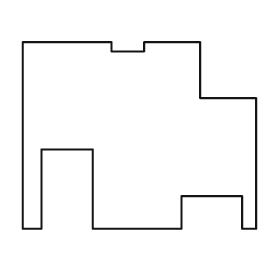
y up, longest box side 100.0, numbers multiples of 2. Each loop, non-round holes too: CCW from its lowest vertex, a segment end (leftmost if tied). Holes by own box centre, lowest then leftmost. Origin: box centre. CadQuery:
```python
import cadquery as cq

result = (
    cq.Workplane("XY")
    .moveTo(-50.0, -40.0)
    .lineTo(-42.0, -40.0)
    .lineTo(-42.0, -6.0)
    .lineTo(-20.0, -6.0)
    .lineTo(-20.0, -40.0)
    .lineTo(18.0, -40.0)
    .lineTo(18.0, -26.0)
    .lineTo(44.0, -26.0)
    .lineTo(44.0, -40.0)
    .lineTo(50.0, -40.0)
    .lineTo(50.0, 16.0)
    .lineTo(26.0, 16.0)
    .lineTo(26.0, 40.0)
    .lineTo(2.0, 40.0)
    .lineTo(2.0, 36.0)
    .lineTo(-12.0, 36.0)
    .lineTo(-12.0, 40.0)
    .lineTo(-50.0, 40.0)
    .close()
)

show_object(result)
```